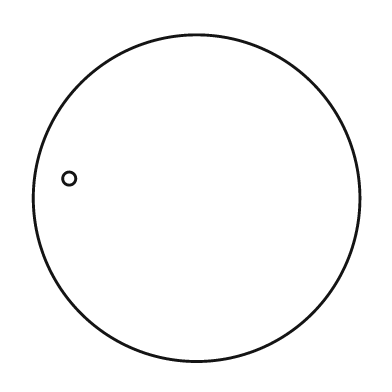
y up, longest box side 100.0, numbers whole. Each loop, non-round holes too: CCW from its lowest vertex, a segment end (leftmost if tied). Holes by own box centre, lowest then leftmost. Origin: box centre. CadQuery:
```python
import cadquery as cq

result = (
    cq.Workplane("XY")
    .moveTo(0.0, 0.0)
    .circle(50.0)
    .moveTo(-39.0, 6.0)
    .circle(2.0)
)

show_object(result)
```